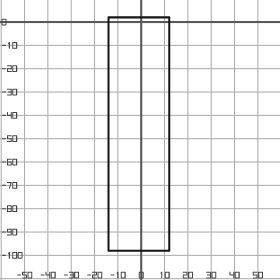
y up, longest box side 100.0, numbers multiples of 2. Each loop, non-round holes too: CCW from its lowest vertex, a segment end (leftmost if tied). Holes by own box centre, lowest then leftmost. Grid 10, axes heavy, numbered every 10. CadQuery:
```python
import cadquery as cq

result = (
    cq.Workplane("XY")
    .moveTo(-14.0, -98.0)
    .lineTo(12.0, -98.0)
    .lineTo(12.0, 2.0)
    .lineTo(-14.0, 2.0)
    .close()
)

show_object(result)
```